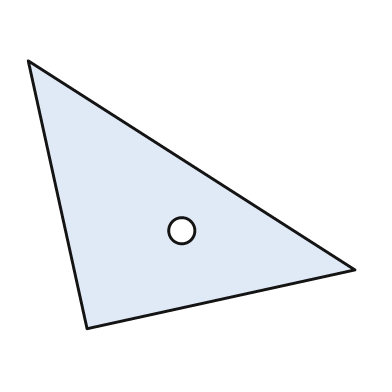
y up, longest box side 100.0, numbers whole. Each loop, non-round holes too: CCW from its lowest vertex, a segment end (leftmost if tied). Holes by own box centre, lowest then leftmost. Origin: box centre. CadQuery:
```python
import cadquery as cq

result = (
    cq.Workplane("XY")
    .moveTo(-32.0, -41.0)
    .lineTo(50.0, -23.0)
    .lineTo(-50.0, 41.0)
    .close()
    .moveTo(-3.0, -11.0)
    .circle(4.0)
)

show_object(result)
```